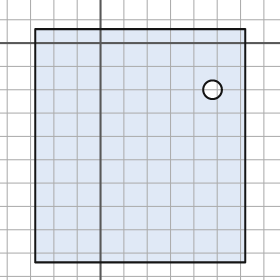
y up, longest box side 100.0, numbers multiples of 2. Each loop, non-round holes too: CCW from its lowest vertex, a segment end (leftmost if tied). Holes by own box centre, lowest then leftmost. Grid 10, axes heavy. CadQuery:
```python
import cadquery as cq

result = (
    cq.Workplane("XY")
    .moveTo(-28.0, -94.0)
    .lineTo(62.0, -94.0)
    .lineTo(62.0, 6.0)
    .lineTo(-28.0, 6.0)
    .close()
    .moveTo(48.0, -20.0)
    .circle(4.0)
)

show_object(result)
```